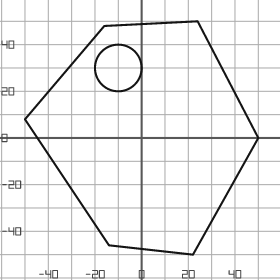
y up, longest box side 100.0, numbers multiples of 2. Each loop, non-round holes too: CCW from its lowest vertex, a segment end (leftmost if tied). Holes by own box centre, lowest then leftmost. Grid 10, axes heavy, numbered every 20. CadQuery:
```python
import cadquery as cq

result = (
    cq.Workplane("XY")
    .moveTo(22.0, -50.0)
    .lineTo(50.0, 0.0)
    .lineTo(24.0, 50.0)
    .lineTo(-16.0, 48.0)
    .lineTo(-50.0, 8.0)
    .lineTo(-14.0, -46.0)
    .close()
    .moveTo(-10.0, 30.0)
    .circle(10.0)
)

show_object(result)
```